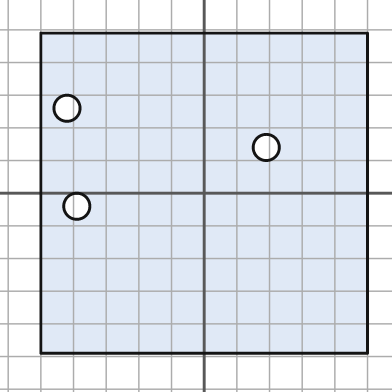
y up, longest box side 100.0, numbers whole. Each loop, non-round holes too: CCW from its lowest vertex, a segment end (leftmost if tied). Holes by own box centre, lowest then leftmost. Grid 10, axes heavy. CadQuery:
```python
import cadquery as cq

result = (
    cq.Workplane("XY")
    .moveTo(-50.0, -49.0)
    .lineTo(50.0, -49.0)
    .lineTo(50.0, 49.0)
    .lineTo(-50.0, 49.0)
    .close()
    .moveTo(-39.0, -4.0)
    .circle(4.0)
    .moveTo(19.0, 14.0)
    .circle(4.0)
    .moveTo(-42.0, 26.0)
    .circle(4.0)
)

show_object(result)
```